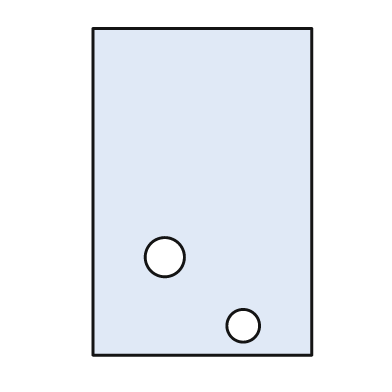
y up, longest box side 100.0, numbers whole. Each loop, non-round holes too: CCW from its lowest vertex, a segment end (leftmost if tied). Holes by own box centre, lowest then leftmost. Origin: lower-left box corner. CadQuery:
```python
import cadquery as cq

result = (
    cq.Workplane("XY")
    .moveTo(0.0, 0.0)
    .lineTo(67.0, 0.0)
    .lineTo(67.0, 100.0)
    .lineTo(0.0, 100.0)
    .close()
    .moveTo(46.0, 9.0)
    .circle(5.0)
    .moveTo(22.0, 30.0)
    .circle(6.0)
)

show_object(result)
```